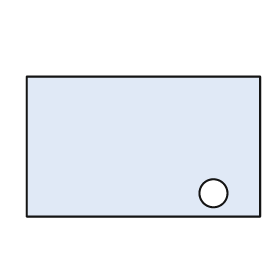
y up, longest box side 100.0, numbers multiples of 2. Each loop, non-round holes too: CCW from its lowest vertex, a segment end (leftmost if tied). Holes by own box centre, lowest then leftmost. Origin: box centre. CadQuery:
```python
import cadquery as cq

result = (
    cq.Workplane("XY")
    .moveTo(-50.0, -30.0)
    .lineTo(50.0, -30.0)
    .lineTo(50.0, 30.0)
    .lineTo(-50.0, 30.0)
    .close()
    .moveTo(30.0, -20.0)
    .circle(6.0)
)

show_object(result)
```